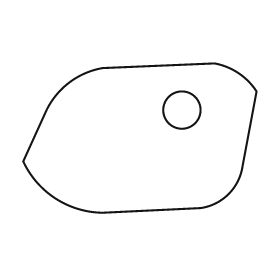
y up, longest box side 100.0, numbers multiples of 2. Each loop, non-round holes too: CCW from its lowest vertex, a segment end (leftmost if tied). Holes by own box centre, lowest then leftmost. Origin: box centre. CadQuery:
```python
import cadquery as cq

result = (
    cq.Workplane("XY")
    .moveTo(-16.0, -32.0)
    .lineTo(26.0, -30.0)
    .threePointArc((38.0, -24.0), (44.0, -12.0))
    .lineTo(50.0, 20.0)
    .threePointArc((42.0, 28.0), (32.0, 32.0))
    .lineTo(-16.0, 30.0)
    .threePointArc((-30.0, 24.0), (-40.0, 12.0))
    .lineTo(-50.0, -10.0)
    .threePointArc((-36.0, -26.0), (-16.0, -32.0))
    .close()
    .moveTo(18.0, 12.0)
    .circle(8.0)
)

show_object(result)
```